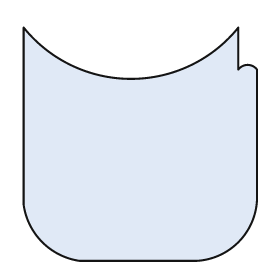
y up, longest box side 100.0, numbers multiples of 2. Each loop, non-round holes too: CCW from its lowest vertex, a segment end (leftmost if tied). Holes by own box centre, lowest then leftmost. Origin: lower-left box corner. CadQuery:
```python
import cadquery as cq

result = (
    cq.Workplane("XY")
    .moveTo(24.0, 0.0)
    .lineTo(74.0, 0.0)
    .threePointArc((92.0, 8.0), (100.0, 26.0))
    .lineTo(100.0, 82.0)
    .threePointArc((96.0, 84.0), (92.0, 82.0))
    .lineTo(92.0, 100.0)
    .threePointArc((46.0, 78.0), (0.0, 100.0))
    .lineTo(0.0, 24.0)
    .threePointArc((8.0, 8.0), (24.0, 0.0))
    .close()
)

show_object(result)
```